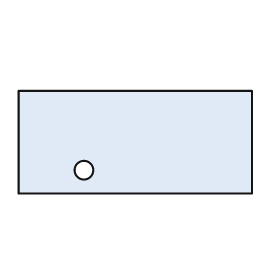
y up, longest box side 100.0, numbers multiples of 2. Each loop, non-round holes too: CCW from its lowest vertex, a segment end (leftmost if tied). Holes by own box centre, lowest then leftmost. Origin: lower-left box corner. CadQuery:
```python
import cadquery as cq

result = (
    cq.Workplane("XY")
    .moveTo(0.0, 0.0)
    .lineTo(100.0, 0.0)
    .lineTo(100.0, 44.0)
    .lineTo(0.0, 44.0)
    .close()
    .moveTo(28.0, 10.0)
    .circle(4.0)
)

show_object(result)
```